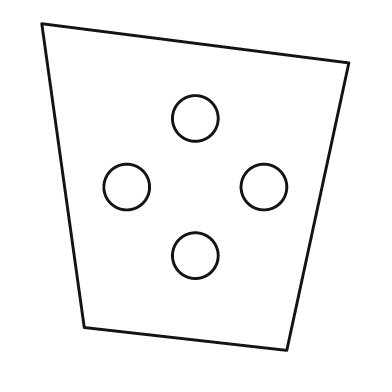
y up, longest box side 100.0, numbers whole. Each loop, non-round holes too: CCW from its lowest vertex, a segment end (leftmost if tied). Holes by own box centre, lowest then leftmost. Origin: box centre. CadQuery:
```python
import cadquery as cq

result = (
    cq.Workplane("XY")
    .moveTo(28.0, -50.0)
    .lineTo(47.0, 38.0)
    .lineTo(-47.0, 50.0)
    .lineTo(-34.0, -43.0)
    .close()
    .moveTo(0.0, -21.0)
    .circle(7.0)
    .moveTo(-21.0, 0.0)
    .circle(7.0)
    .moveTo(21.0, 0.0)
    .circle(7.0)
    .moveTo(0.0, 21.0)
    .circle(7.0)
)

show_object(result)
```